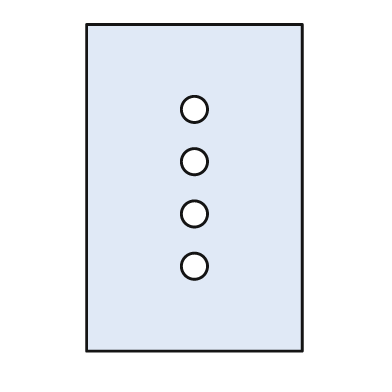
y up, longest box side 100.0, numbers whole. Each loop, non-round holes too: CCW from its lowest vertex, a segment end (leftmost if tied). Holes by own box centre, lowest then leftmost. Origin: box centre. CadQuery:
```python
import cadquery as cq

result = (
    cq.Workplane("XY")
    .moveTo(-33.0, -50.0)
    .lineTo(33.0, -50.0)
    .lineTo(33.0, 50.0)
    .lineTo(-33.0, 50.0)
    .close()
    .moveTo(0.0, -24.0)
    .circle(4.0)
    .moveTo(0.0, -8.0)
    .circle(4.0)
    .moveTo(0.0, 8.0)
    .circle(4.0)
    .moveTo(0.0, 24.0)
    .circle(4.0)
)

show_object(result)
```